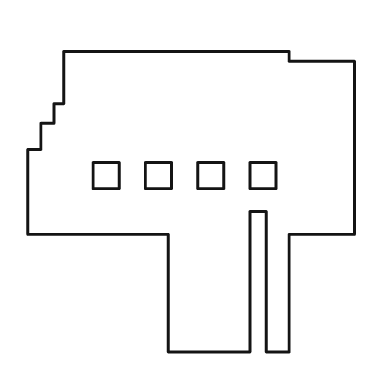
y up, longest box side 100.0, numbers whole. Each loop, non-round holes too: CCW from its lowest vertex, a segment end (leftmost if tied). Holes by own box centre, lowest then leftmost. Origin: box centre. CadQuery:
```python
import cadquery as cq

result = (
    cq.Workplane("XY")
    .moveTo(-7.0, -46.0)
    .lineTo(18.0, -46.0)
    .lineTo(18.0, -3.0)
    .lineTo(23.0, -3.0)
    .lineTo(23.0, -46.0)
    .lineTo(30.0, -46.0)
    .lineTo(30.0, -10.0)
    .lineTo(50.0, -10.0)
    .lineTo(50.0, 43.0)
    .lineTo(30.0, 43.0)
    .lineTo(30.0, 46.0)
    .lineTo(-39.0, 46.0)
    .lineTo(-39.0, 30.0)
    .lineTo(-42.0, 30.0)
    .lineTo(-42.0, 24.0)
    .lineTo(-46.0, 24.0)
    .lineTo(-46.0, 16.0)
    .lineTo(-50.0, 16.0)
    .lineTo(-50.0, -10.0)
    .lineTo(-7.0, -10.0)
    .close()
    .moveTo(-30.0, 4.0)
    .lineTo(-22.0, 4.0)
    .lineTo(-22.0, 12.0)
    .lineTo(-30.0, 12.0)
    .close()
    .moveTo(-14.0, 4.0)
    .lineTo(-6.0, 4.0)
    .lineTo(-6.0, 12.0)
    .lineTo(-14.0, 12.0)
    .close()
    .moveTo(2.0, 4.0)
    .lineTo(10.0, 4.0)
    .lineTo(10.0, 12.0)
    .lineTo(2.0, 12.0)
    .close()
    .moveTo(18.0, 4.0)
    .lineTo(26.0, 4.0)
    .lineTo(26.0, 12.0)
    .lineTo(18.0, 12.0)
    .close()
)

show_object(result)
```